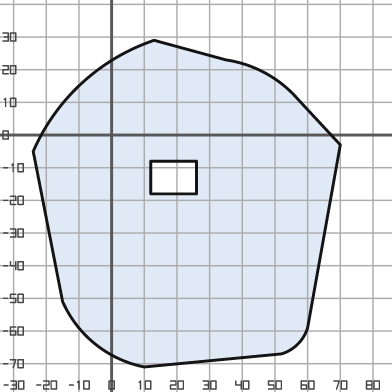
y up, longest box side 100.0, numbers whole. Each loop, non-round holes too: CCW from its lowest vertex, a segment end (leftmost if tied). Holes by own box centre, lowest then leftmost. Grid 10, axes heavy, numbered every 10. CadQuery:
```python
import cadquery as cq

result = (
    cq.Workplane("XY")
    .moveTo(10.0, -71.0)
    .lineTo(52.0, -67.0)
    .threePointArc((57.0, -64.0), (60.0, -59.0))
    .lineTo(70.0, -3.0)
    .lineTo(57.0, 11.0)
    .threePointArc((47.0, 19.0), (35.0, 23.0))
    .lineTo(13.0, 29.0)
    .threePointArc((-9.0, 16.0), (-24.0, -5.0))
    .lineTo(-15.0, -51.0)
    .threePointArc((-5.0, -64.0), (10.0, -71.0))
    .close()
    .moveTo(12.0, -18.0)
    .lineTo(26.0, -18.0)
    .lineTo(26.0, -8.0)
    .lineTo(12.0, -8.0)
    .close()
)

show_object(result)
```